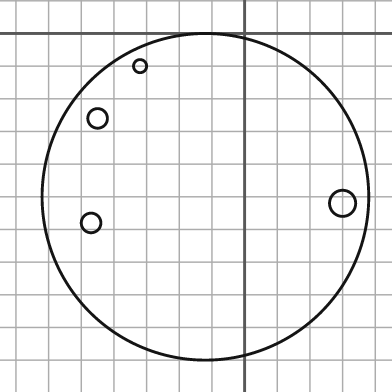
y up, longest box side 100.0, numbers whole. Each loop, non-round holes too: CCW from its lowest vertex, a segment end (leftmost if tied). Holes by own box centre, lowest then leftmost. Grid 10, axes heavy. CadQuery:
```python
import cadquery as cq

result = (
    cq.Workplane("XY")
    .moveTo(-12.0, -50.0)
    .circle(50.0)
    .moveTo(-47.0, -58.0)
    .circle(3.0)
    .moveTo(30.0, -52.0)
    .circle(4.0)
    .moveTo(-45.0, -26.0)
    .circle(3.0)
    .moveTo(-32.0, -10.0)
    .circle(2.0)
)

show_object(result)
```